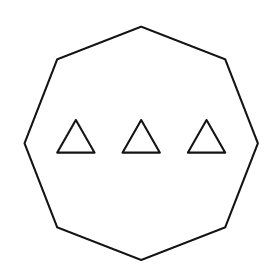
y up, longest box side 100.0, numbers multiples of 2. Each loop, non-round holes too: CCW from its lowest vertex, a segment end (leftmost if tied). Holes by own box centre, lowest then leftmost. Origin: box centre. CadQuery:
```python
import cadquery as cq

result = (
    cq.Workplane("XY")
    .moveTo(0.0, -50.0)
    .lineTo(36.0, -36.0)
    .lineTo(50.0, 0.0)
    .lineTo(36.0, 36.0)
    .lineTo(0.0, 50.0)
    .lineTo(-36.0, 36.0)
    .lineTo(-50.0, 0.0)
    .lineTo(-36.0, -36.0)
    .close()
    .moveTo(-36.0, -4.0)
    .lineTo(-20.0, -4.0)
    .lineTo(-28.0, 10.0)
    .close()
    .moveTo(-8.0, -4.0)
    .lineTo(8.0, -4.0)
    .lineTo(0.0, 10.0)
    .close()
    .moveTo(20.0, -4.0)
    .lineTo(36.0, -4.0)
    .lineTo(28.0, 10.0)
    .close()
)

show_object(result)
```